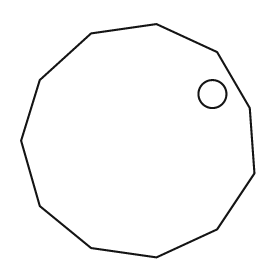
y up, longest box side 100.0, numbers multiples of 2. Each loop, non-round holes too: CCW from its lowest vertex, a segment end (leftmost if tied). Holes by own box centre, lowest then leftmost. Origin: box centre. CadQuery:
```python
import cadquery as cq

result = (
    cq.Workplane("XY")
    .moveTo(8.0, -50.0)
    .lineTo(34.0, -38.0)
    .lineTo(50.0, -14.0)
    .lineTo(48.0, 14.0)
    .lineTo(34.0, 38.0)
    .lineTo(8.0, 50.0)
    .lineTo(-20.0, 46.0)
    .lineTo(-42.0, 26.0)
    .lineTo(-50.0, 0.0)
    .lineTo(-42.0, -28.0)
    .lineTo(-20.0, -46.0)
    .close()
    .moveTo(32.0, 20.0)
    .circle(6.0)
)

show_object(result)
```